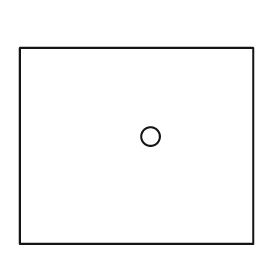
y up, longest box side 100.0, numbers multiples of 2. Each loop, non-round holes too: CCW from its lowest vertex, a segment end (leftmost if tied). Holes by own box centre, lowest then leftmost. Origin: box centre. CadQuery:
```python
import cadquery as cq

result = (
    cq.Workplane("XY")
    .moveTo(-50.0, -42.0)
    .lineTo(50.0, -42.0)
    .lineTo(50.0, 42.0)
    .lineTo(-50.0, 42.0)
    .close()
    .moveTo(6.0, 4.0)
    .circle(4.0)
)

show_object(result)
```